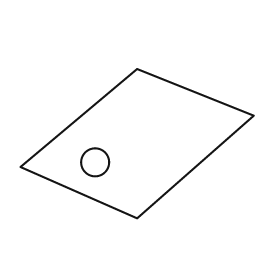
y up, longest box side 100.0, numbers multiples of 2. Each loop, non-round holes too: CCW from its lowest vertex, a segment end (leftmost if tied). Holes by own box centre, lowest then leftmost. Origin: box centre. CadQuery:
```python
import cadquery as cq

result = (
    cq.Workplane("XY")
    .moveTo(0.0, -32.0)
    .lineTo(50.0, 12.0)
    .lineTo(0.0, 32.0)
    .lineTo(-50.0, -10.0)
    .close()
    .moveTo(-18.0, -8.0)
    .circle(6.0)
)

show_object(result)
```